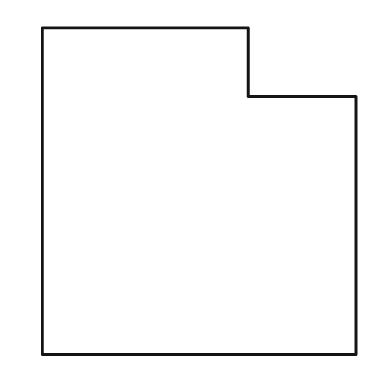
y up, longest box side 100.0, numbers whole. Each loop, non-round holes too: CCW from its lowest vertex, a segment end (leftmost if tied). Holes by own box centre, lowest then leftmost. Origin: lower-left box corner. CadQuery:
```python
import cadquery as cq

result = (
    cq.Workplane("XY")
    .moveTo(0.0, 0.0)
    .lineTo(96.0, 0.0)
    .lineTo(96.0, 79.0)
    .lineTo(63.0, 79.0)
    .lineTo(63.0, 100.0)
    .lineTo(0.0, 100.0)
    .close()
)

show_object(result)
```